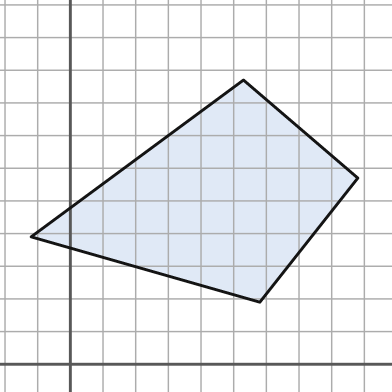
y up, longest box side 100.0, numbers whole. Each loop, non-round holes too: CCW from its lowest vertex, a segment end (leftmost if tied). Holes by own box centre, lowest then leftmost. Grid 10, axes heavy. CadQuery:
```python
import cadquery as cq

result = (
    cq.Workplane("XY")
    .moveTo(58.0, 19.0)
    .lineTo(88.0, 57.0)
    .lineTo(53.0, 87.0)
    .lineTo(-12.0, 39.0)
    .close()
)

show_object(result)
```